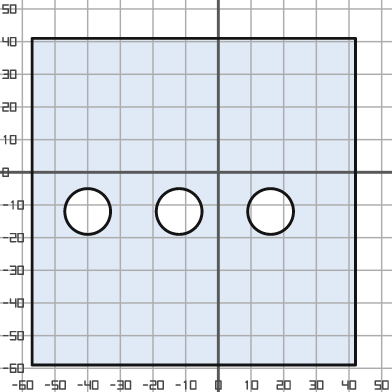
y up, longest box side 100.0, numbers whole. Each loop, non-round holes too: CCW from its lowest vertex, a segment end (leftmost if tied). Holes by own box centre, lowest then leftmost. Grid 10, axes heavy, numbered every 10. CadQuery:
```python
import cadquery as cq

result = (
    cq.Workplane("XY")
    .moveTo(-57.0, -59.0)
    .lineTo(42.0, -59.0)
    .lineTo(42.0, 41.0)
    .lineTo(-57.0, 41.0)
    .close()
    .moveTo(-40.0, -12.0)
    .circle(7.0)
    .moveTo(-12.0, -12.0)
    .circle(7.0)
    .moveTo(16.0, -12.0)
    .circle(7.0)
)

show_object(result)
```